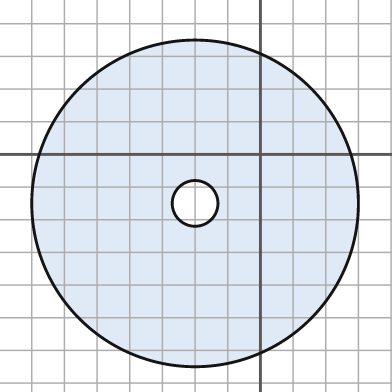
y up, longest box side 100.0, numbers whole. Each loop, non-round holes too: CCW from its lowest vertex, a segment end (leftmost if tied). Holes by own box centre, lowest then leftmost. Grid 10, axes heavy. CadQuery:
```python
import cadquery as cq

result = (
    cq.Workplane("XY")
    .moveTo(-20.0, -15.0)
    .circle(50.0)
    .moveTo(-20.0, -15.0)
    .circle(7.0)
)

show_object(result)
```